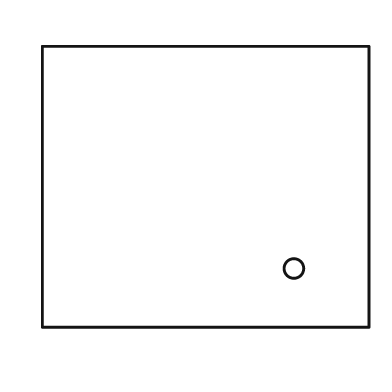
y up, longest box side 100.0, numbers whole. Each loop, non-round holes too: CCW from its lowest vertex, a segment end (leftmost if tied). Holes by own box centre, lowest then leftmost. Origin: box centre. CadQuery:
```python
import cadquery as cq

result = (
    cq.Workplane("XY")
    .moveTo(-50.0, -43.0)
    .lineTo(50.0, -43.0)
    .lineTo(50.0, 43.0)
    .lineTo(-50.0, 43.0)
    .close()
    .moveTo(27.0, -25.0)
    .circle(3.0)
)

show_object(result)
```